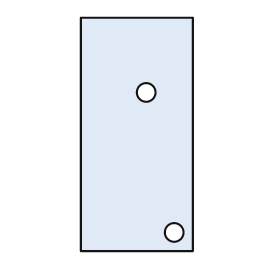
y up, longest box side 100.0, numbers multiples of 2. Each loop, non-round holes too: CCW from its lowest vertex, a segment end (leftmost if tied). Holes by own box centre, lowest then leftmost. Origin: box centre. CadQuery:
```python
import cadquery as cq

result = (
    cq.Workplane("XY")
    .moveTo(-24.0, -50.0)
    .lineTo(24.0, -50.0)
    .lineTo(24.0, 50.0)
    .lineTo(-24.0, 50.0)
    .close()
    .moveTo(16.0, -42.0)
    .circle(4.0)
    .moveTo(4.0, 18.0)
    .circle(4.0)
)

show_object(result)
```